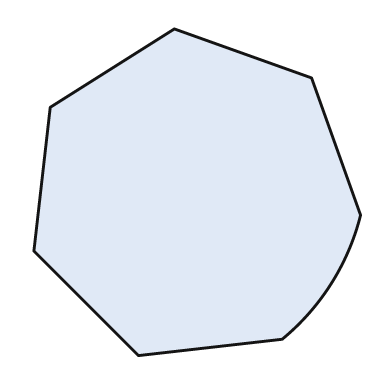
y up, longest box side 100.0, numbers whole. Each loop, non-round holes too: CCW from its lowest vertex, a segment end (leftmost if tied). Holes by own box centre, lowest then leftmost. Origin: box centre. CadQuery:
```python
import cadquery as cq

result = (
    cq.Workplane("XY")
    .moveTo(-18.0, -50.0)
    .lineTo(26.0, -45.0)
    .threePointArc((41.0, -28.0), (50.0, -7.0))
    .lineTo(35.0, 35.0)
    .lineTo(-7.0, 50.0)
    .lineTo(-45.0, 26.0)
    .lineTo(-50.0, -18.0)
    .close()
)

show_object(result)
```